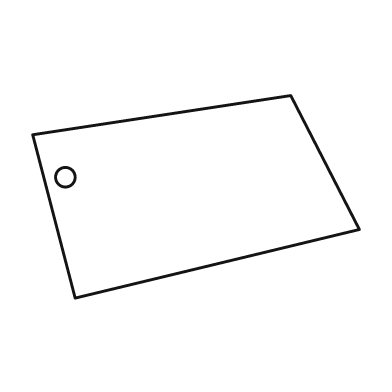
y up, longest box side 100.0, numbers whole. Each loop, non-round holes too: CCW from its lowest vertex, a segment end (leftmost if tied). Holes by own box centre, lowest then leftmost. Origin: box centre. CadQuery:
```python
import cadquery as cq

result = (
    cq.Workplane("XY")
    .moveTo(-37.0, -31.0)
    .lineTo(50.0, -10.0)
    .lineTo(29.0, 31.0)
    .lineTo(-50.0, 19.0)
    .close()
    .moveTo(-40.0, 6.0)
    .circle(3.0)
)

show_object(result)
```